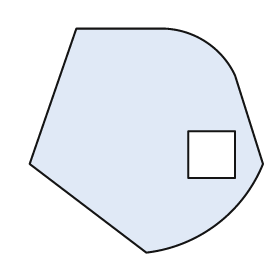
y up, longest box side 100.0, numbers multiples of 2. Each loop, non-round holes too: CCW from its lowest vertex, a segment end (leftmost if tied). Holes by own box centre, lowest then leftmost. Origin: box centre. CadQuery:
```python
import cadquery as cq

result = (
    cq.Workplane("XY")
    .moveTo(0.0, -48.0)
    .threePointArc((30.0, -36.0), (50.0, -10.0))
    .lineTo(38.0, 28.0)
    .threePointArc((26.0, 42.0), (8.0, 48.0))
    .lineTo(-30.0, 48.0)
    .lineTo(-50.0, -10.0)
    .close()
    .moveTo(18.0, -16.0)
    .lineTo(38.0, -16.0)
    .lineTo(38.0, 4.0)
    .lineTo(18.0, 4.0)
    .close()
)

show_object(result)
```